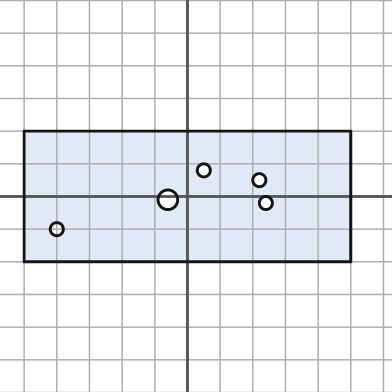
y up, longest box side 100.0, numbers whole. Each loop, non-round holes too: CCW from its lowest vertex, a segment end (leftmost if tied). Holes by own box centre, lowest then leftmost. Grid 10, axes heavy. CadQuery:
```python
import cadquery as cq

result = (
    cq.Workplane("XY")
    .moveTo(-50.0, -20.0)
    .lineTo(50.0, -20.0)
    .lineTo(50.0, 20.0)
    .lineTo(-50.0, 20.0)
    .close()
    .moveTo(-40.0, -10.0)
    .circle(2.0)
    .moveTo(24.0, -2.0)
    .circle(2.0)
    .moveTo(-6.0, -1.0)
    .circle(3.0)
    .moveTo(22.0, 5.0)
    .circle(2.0)
    .moveTo(5.0, 8.0)
    .circle(2.0)
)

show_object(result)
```